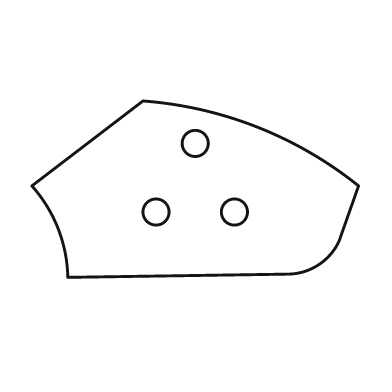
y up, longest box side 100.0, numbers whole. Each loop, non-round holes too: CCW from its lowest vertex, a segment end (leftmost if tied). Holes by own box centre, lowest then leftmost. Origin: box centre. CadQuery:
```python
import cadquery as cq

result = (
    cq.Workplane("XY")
    .moveTo(-39.0, -27.0)
    .lineTo(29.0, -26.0)
    .threePointArc((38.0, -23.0), (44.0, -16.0))
    .lineTo(50.0, 1.0)
    .threePointArc((19.0, 19.0), (-16.0, 27.0))
    .lineTo(-50.0, 1.0)
    .threePointArc((-42.0, -12.0), (-39.0, -27.0))
    .close()
    .moveTo(-12.0, -7.0)
    .circle(4.0)
    .moveTo(12.0, -7.0)
    .circle(4.0)
    .moveTo(0.0, 14.0)
    .circle(4.0)
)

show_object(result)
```